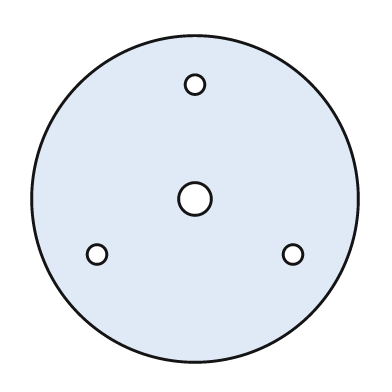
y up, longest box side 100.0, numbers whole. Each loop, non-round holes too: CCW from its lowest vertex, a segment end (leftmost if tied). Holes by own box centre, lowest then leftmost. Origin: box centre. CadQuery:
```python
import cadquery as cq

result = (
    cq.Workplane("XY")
    .moveTo(0.0, 0.0)
    .circle(50.0)
    .moveTo(-30.0, -17.0)
    .circle(3.0)
    .moveTo(30.0, -17.0)
    .circle(3.0)
    .moveTo(0.0, 0.0)
    .circle(5.0)
    .moveTo(0.0, 35.0)
    .circle(3.0)
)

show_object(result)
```